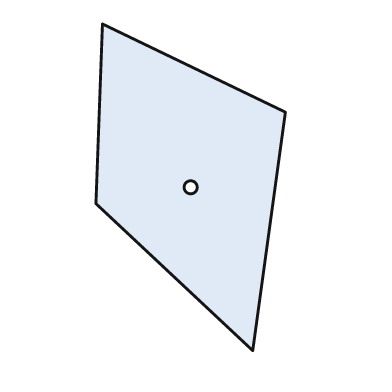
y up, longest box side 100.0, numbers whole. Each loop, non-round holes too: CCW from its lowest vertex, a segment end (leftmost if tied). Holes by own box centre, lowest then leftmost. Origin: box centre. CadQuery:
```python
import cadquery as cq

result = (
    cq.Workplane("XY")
    .moveTo(19.0, -50.0)
    .lineTo(29.0, 23.0)
    .lineTo(-27.0, 50.0)
    .lineTo(-29.0, -5.0)
    .close()
    .moveTo(0.0, 0.0)
    .circle(2.0)
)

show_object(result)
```